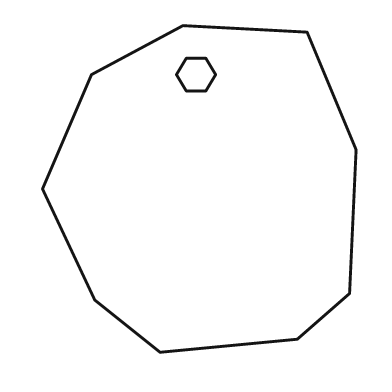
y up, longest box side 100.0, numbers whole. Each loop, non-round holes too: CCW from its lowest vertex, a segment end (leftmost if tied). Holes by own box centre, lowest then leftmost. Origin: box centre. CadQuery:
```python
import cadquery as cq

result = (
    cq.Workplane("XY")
    .moveTo(-12.0, -50.0)
    .lineTo(30.0, -46.0)
    .lineTo(46.0, -32.0)
    .lineTo(48.0, 12.0)
    .lineTo(33.0, 48.0)
    .lineTo(-5.0, 50.0)
    .lineTo(-33.0, 35.0)
    .lineTo(-48.0, 0.0)
    .lineTo(-32.0, -34.0)
    .close()
    .moveTo(-4.0, 30.0)
    .lineTo(2.0, 30.0)
    .lineTo(5.0, 35.0)
    .lineTo(2.0, 40.0)
    .lineTo(-4.0, 40.0)
    .lineTo(-7.0, 35.0)
    .close()
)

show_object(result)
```